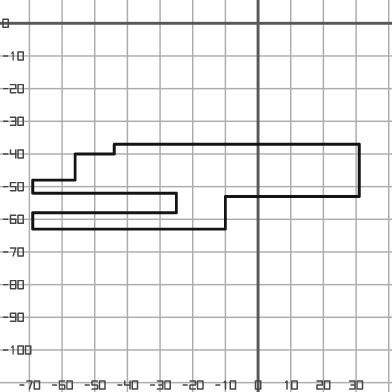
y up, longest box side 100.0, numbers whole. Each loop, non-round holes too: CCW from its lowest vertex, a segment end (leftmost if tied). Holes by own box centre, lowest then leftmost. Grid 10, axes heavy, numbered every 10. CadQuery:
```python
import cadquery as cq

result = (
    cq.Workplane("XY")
    .moveTo(-69.0, -63.0)
    .lineTo(-10.0, -63.0)
    .lineTo(-10.0, -53.0)
    .lineTo(31.0, -53.0)
    .lineTo(31.0, -37.0)
    .lineTo(-44.0, -37.0)
    .lineTo(-44.0, -40.0)
    .lineTo(-56.0, -40.0)
    .lineTo(-56.0, -48.0)
    .lineTo(-69.0, -48.0)
    .lineTo(-69.0, -52.0)
    .lineTo(-25.0, -52.0)
    .lineTo(-25.0, -58.0)
    .lineTo(-69.0, -58.0)
    .close()
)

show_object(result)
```